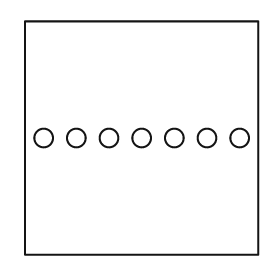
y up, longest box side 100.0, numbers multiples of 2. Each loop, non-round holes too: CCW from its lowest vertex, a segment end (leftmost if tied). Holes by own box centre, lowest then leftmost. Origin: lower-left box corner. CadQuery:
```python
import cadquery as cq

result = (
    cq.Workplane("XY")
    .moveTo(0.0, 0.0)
    .lineTo(100.0, 0.0)
    .lineTo(100.0, 100.0)
    .lineTo(0.0, 100.0)
    .close()
    .moveTo(8.0, 50.0)
    .circle(4.0)
    .moveTo(22.0, 50.0)
    .circle(4.0)
    .moveTo(36.0, 50.0)
    .circle(4.0)
    .moveTo(50.0, 50.0)
    .circle(4.0)
    .moveTo(64.0, 50.0)
    .circle(4.0)
    .moveTo(78.0, 50.0)
    .circle(4.0)
    .moveTo(92.0, 50.0)
    .circle(4.0)
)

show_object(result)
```